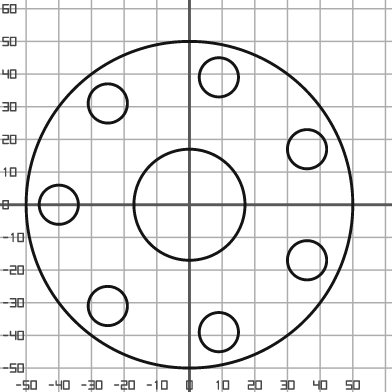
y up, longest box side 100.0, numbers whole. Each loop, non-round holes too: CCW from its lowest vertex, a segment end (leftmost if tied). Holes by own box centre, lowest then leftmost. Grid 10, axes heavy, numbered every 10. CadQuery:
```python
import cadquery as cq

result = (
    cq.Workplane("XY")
    .moveTo(0.0, 0.0)
    .circle(50.0)
    .moveTo(9.0, -39.0)
    .circle(6.0)
    .moveTo(-25.0, -31.0)
    .circle(6.0)
    .moveTo(36.0, -17.0)
    .circle(6.0)
    .moveTo(-40.0, 0.0)
    .circle(6.0)
    .moveTo(0.0, 0.0)
    .circle(17.0)
    .moveTo(36.0, 17.0)
    .circle(6.0)
    .moveTo(-25.0, 31.0)
    .circle(6.0)
    .moveTo(9.0, 39.0)
    .circle(6.0)
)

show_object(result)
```